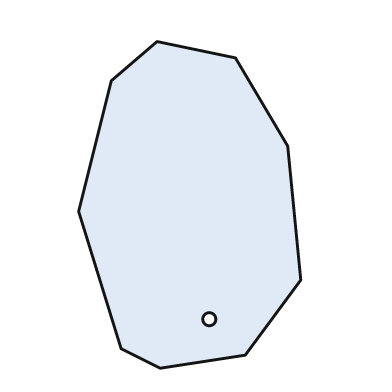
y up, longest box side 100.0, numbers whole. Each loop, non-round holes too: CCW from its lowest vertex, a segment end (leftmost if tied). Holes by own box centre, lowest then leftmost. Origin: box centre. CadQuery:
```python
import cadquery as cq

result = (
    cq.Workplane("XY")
    .moveTo(-9.0, -50.0)
    .lineTo(17.0, -46.0)
    .lineTo(34.0, -23.0)
    .lineTo(30.0, 18.0)
    .lineTo(14.0, 45.0)
    .lineTo(-10.0, 50.0)
    .lineTo(-24.0, 38.0)
    .lineTo(-34.0, -2.0)
    .lineTo(-21.0, -44.0)
    .close()
    .moveTo(6.0, -35.0)
    .circle(2.0)
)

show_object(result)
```